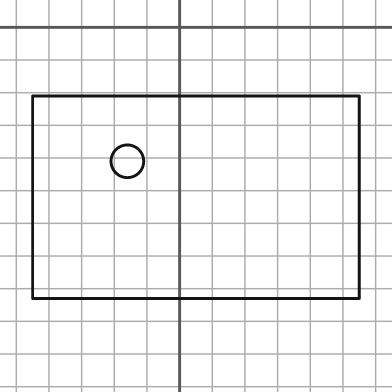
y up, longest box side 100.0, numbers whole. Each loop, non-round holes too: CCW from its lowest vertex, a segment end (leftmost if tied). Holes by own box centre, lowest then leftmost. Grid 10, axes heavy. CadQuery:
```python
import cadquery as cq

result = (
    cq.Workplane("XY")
    .moveTo(-45.0, -83.0)
    .lineTo(55.0, -83.0)
    .lineTo(55.0, -21.0)
    .lineTo(-45.0, -21.0)
    .close()
    .moveTo(-16.0, -41.0)
    .circle(5.0)
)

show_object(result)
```